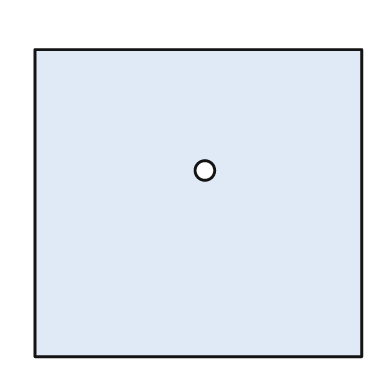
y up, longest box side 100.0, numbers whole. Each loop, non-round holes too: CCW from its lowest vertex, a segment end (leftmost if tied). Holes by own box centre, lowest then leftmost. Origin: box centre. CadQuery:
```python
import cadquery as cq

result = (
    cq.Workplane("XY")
    .moveTo(-50.0, -47.0)
    .lineTo(50.0, -47.0)
    .lineTo(50.0, 47.0)
    .lineTo(-50.0, 47.0)
    .close()
    .moveTo(2.0, 10.0)
    .circle(3.0)
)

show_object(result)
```